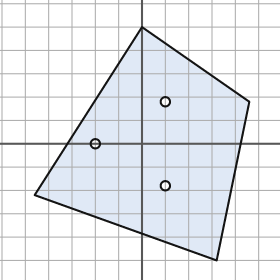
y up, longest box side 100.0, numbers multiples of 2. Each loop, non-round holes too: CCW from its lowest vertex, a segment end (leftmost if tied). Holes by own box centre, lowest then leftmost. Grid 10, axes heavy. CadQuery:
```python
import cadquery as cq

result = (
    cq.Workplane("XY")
    .moveTo(32.0, -50.0)
    .lineTo(46.0, 18.0)
    .lineTo(0.0, 50.0)
    .lineTo(-46.0, -22.0)
    .close()
    .moveTo(10.0, -18.0)
    .circle(2.0)
    .moveTo(-20.0, 0.0)
    .circle(2.0)
    .moveTo(10.0, 18.0)
    .circle(2.0)
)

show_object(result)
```